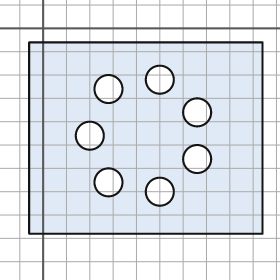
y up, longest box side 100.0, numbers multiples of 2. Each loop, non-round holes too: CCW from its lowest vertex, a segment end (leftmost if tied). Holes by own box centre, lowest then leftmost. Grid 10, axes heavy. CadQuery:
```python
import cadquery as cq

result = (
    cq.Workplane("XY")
    .moveTo(-6.0, -88.0)
    .lineTo(94.0, -88.0)
    .lineTo(94.0, -6.0)
    .lineTo(-6.0, -6.0)
    .close()
    .moveTo(50.0, -70.0)
    .circle(6.0)
    .moveTo(28.0, -66.0)
    .circle(6.0)
    .moveTo(66.0, -56.0)
    .circle(6.0)
    .moveTo(20.0, -46.0)
    .circle(6.0)
    .moveTo(66.0, -36.0)
    .circle(6.0)
    .moveTo(28.0, -26.0)
    .circle(6.0)
    .moveTo(50.0, -22.0)
    .circle(6.0)
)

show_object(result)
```